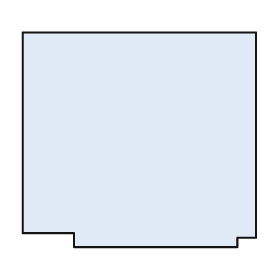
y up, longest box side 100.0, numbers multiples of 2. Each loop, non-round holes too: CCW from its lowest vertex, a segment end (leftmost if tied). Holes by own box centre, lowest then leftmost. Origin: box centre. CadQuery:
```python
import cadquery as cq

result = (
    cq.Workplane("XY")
    .moveTo(-28.0, -46.0)
    .lineTo(42.0, -46.0)
    .lineTo(42.0, -42.0)
    .lineTo(50.0, -42.0)
    .lineTo(50.0, 46.0)
    .lineTo(-50.0, 46.0)
    .lineTo(-50.0, -40.0)
    .lineTo(-28.0, -40.0)
    .close()
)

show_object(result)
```